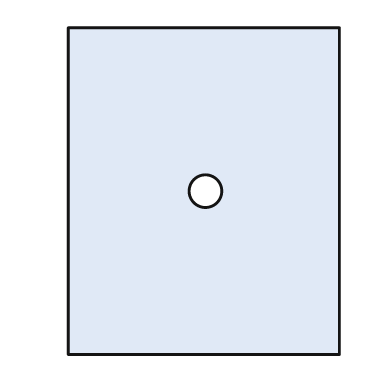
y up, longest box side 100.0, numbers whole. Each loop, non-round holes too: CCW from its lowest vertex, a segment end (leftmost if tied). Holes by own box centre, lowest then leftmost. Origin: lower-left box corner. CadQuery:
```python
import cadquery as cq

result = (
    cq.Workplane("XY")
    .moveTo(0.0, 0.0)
    .lineTo(83.0, 0.0)
    .lineTo(83.0, 100.0)
    .lineTo(0.0, 100.0)
    .close()
    .moveTo(42.0, 50.0)
    .circle(5.0)
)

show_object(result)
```